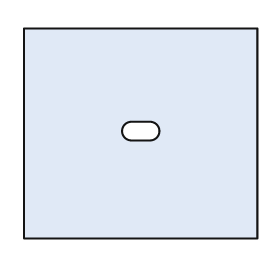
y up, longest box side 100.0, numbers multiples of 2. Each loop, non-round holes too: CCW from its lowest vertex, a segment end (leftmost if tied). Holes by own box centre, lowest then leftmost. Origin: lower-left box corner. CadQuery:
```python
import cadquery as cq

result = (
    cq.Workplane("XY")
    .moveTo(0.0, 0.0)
    .lineTo(100.0, 0.0)
    .lineTo(100.0, 90.0)
    .lineTo(0.0, 90.0)
    .close()
    .moveTo(46.0, 42.0)
    .lineTo(54.0, 42.0)
    .threePointArc((58.0, 46.0), (54.0, 50.0))
    .lineTo(46.0, 50.0)
    .threePointArc((42.0, 46.0), (46.0, 42.0))
    .close()
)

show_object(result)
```